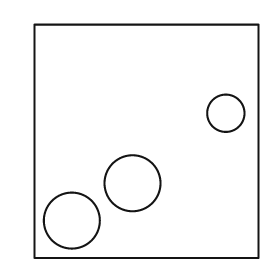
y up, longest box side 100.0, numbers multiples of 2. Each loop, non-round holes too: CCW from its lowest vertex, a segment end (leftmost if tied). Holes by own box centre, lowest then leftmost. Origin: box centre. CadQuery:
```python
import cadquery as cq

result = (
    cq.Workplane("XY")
    .moveTo(-48.0, -50.0)
    .lineTo(48.0, -50.0)
    .lineTo(48.0, 50.0)
    .lineTo(-48.0, 50.0)
    .close()
    .moveTo(-32.0, -34.0)
    .circle(12.0)
    .moveTo(-6.0, -18.0)
    .circle(12.0)
    .moveTo(34.0, 12.0)
    .circle(8.0)
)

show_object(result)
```